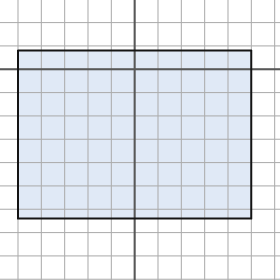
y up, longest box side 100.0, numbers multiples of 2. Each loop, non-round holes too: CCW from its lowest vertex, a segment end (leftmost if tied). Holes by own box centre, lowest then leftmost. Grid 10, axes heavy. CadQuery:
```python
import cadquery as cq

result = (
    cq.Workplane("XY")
    .moveTo(-50.0, -64.0)
    .lineTo(50.0, -64.0)
    .lineTo(50.0, 8.0)
    .lineTo(-50.0, 8.0)
    .close()
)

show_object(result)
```